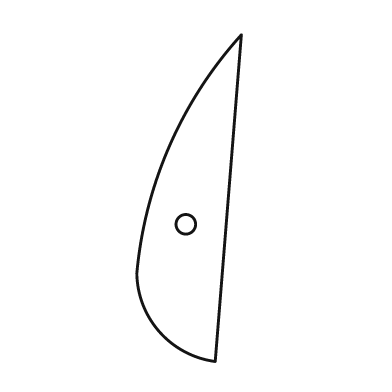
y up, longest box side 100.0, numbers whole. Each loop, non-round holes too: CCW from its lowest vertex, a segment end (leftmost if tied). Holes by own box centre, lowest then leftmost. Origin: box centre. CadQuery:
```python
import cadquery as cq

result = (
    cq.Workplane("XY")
    .moveTo(8.0, -50.0)
    .lineTo(16.0, 50.0)
    .threePointArc((-6.0, 16.0), (-16.0, -23.0))
    .threePointArc((-9.0, -41.0), (8.0, -50.0))
    .close()
    .moveTo(-1.0, -8.0)
    .circle(3.0)
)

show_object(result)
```